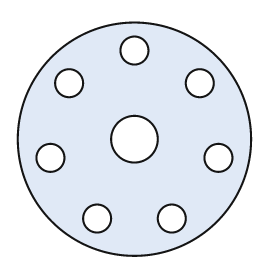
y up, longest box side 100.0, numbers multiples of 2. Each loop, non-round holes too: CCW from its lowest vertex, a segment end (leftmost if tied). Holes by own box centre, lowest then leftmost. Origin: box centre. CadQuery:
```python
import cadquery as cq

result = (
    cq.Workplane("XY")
    .moveTo(0.0, 0.0)
    .circle(50.0)
    .moveTo(-16.0, -34.0)
    .circle(6.0)
    .moveTo(16.0, -34.0)
    .circle(6.0)
    .moveTo(-36.0, -8.0)
    .circle(6.0)
    .moveTo(36.0, -8.0)
    .circle(6.0)
    .moveTo(0.0, 0.0)
    .circle(10.0)
    .moveTo(-28.0, 24.0)
    .circle(6.0)
    .moveTo(28.0, 24.0)
    .circle(6.0)
    .moveTo(0.0, 38.0)
    .circle(6.0)
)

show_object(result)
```